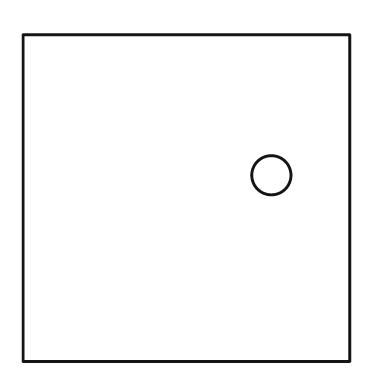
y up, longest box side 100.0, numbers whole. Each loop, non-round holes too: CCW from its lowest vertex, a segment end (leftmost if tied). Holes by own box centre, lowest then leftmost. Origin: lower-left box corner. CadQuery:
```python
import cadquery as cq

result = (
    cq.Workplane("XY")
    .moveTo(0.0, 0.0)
    .lineTo(100.0, 0.0)
    .lineTo(100.0, 100.0)
    .lineTo(0.0, 100.0)
    .close()
    .moveTo(76.0, 57.0)
    .circle(6.0)
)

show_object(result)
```